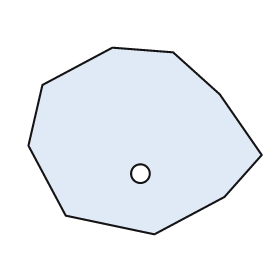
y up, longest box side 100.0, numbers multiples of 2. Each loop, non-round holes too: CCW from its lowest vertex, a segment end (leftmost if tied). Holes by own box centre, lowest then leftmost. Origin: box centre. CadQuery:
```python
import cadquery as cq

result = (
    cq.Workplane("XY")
    .moveTo(4.0, -40.0)
    .lineTo(34.0, -24.0)
    .lineTo(50.0, -6.0)
    .lineTo(32.0, 20.0)
    .lineTo(12.0, 38.0)
    .lineTo(-14.0, 40.0)
    .lineTo(-44.0, 24.0)
    .lineTo(-50.0, -2.0)
    .lineTo(-34.0, -32.0)
    .close()
    .moveTo(-2.0, -14.0)
    .circle(4.0)
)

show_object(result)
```